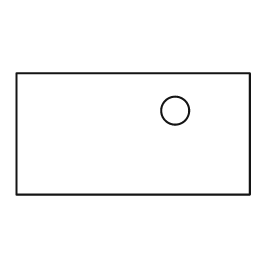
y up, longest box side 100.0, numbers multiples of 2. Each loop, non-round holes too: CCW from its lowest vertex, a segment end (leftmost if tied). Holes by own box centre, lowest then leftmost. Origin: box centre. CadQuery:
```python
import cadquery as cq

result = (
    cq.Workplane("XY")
    .moveTo(-50.0, -26.0)
    .lineTo(50.0, -26.0)
    .lineTo(50.0, 26.0)
    .lineTo(-50.0, 26.0)
    .close()
    .moveTo(18.0, 10.0)
    .circle(6.0)
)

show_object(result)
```